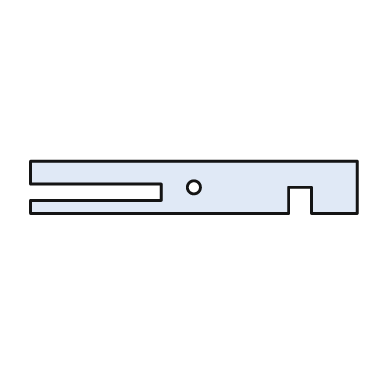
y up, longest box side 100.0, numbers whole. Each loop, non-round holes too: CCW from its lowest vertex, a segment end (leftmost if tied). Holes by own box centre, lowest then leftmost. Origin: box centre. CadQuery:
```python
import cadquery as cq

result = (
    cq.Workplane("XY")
    .moveTo(-50.0, -8.0)
    .lineTo(29.0, -8.0)
    .lineTo(29.0, 0.0)
    .lineTo(36.0, 0.0)
    .lineTo(36.0, -8.0)
    .lineTo(50.0, -8.0)
    .lineTo(50.0, 8.0)
    .lineTo(-50.0, 8.0)
    .lineTo(-50.0, 1.0)
    .lineTo(-10.0, 1.0)
    .lineTo(-10.0, -4.0)
    .lineTo(-50.0, -4.0)
    .close()
    .moveTo(0.0, 0.0)
    .circle(2.0)
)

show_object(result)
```